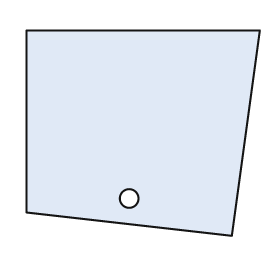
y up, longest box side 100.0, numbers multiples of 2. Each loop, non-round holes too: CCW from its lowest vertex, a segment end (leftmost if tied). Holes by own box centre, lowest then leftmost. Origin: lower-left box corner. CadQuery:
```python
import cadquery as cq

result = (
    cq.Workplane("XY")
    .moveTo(88.0, 0.0)
    .lineTo(100.0, 88.0)
    .lineTo(0.0, 88.0)
    .lineTo(0.0, 10.0)
    .close()
    .moveTo(44.0, 16.0)
    .circle(4.0)
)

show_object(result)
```